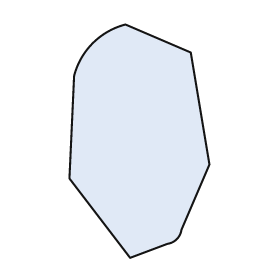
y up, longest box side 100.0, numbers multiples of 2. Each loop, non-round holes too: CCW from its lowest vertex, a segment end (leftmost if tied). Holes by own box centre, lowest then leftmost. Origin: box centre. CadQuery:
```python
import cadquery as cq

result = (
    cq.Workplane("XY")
    .moveTo(-4.0, -50.0)
    .lineTo(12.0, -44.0)
    .threePointArc((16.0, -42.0), (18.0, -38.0))
    .lineTo(30.0, -10.0)
    .lineTo(22.0, 38.0)
    .lineTo(-6.0, 50.0)
    .threePointArc((-20.0, 42.0), (-28.0, 28.0))
    .lineTo(-30.0, -16.0)
    .close()
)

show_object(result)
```